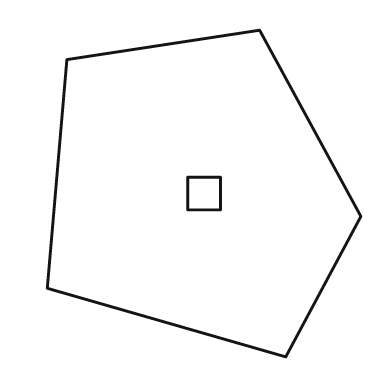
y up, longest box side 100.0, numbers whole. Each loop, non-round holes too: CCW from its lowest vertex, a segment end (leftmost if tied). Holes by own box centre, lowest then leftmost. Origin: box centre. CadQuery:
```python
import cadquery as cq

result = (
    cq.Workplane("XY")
    .moveTo(25.0, -50.0)
    .lineTo(48.0, -7.0)
    .lineTo(17.0, 50.0)
    .lineTo(-42.0, 41.0)
    .lineTo(-48.0, -29.0)
    .close()
    .moveTo(-5.0, -5.0)
    .lineTo(5.0, -5.0)
    .lineTo(5.0, 5.0)
    .lineTo(-5.0, 5.0)
    .close()
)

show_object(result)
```